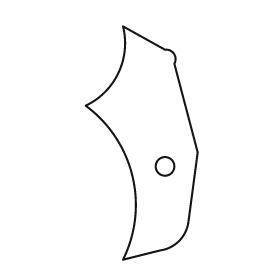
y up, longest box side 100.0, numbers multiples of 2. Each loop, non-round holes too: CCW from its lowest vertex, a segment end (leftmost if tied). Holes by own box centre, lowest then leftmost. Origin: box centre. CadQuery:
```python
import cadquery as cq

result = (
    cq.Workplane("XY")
    .moveTo(-8.0, -50.0)
    .lineTo(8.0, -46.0)
    .threePointArc((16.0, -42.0), (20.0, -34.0))
    .lineTo(24.0, -4.0)
    .lineTo(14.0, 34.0)
    .threePointArc((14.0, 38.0), (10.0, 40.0))
    .lineTo(-8.0, 50.0)
    .threePointArc((-10.0, 30.0), (-24.0, 16.0))
    .threePointArc((-4.0, -14.0), (-8.0, -50.0))
    .close()
    .moveTo(10.0, -10.0)
    .circle(4.0)
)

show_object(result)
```